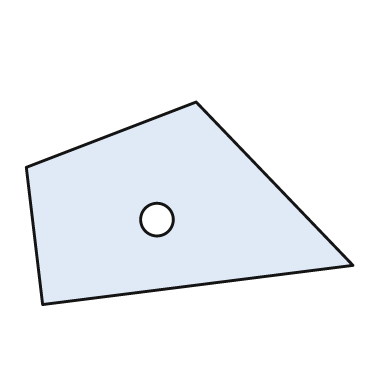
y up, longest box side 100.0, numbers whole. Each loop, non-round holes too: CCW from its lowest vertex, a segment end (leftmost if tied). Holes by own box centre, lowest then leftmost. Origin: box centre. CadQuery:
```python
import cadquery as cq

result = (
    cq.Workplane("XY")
    .moveTo(-45.0, -31.0)
    .lineTo(50.0, -19.0)
    .lineTo(2.0, 31.0)
    .lineTo(-50.0, 11.0)
    .close()
    .moveTo(-10.0, -5.0)
    .circle(5.0)
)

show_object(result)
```